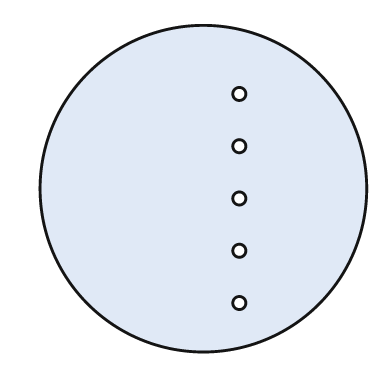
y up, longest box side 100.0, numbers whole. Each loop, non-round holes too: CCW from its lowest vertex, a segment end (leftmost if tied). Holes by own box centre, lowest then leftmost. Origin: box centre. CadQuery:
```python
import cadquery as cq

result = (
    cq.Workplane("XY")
    .moveTo(0.0, 0.0)
    .circle(50.0)
    .moveTo(11.0, -35.0)
    .circle(2.0)
    .moveTo(11.0, -19.0)
    .circle(2.0)
    .moveTo(11.0, -3.0)
    .circle(2.0)
    .moveTo(11.0, 13.0)
    .circle(2.0)
    .moveTo(11.0, 29.0)
    .circle(2.0)
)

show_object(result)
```